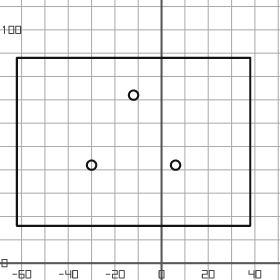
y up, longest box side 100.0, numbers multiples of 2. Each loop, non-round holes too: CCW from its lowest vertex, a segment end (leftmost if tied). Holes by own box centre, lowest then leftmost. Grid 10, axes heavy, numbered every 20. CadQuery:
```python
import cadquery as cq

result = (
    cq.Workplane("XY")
    .moveTo(-62.0, 16.0)
    .lineTo(38.0, 16.0)
    .lineTo(38.0, 88.0)
    .lineTo(-62.0, 88.0)
    .close()
    .moveTo(-30.0, 42.0)
    .circle(2.0)
    .moveTo(6.0, 42.0)
    .circle(2.0)
    .moveTo(-12.0, 72.0)
    .circle(2.0)
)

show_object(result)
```